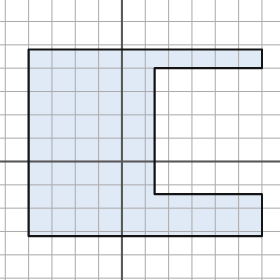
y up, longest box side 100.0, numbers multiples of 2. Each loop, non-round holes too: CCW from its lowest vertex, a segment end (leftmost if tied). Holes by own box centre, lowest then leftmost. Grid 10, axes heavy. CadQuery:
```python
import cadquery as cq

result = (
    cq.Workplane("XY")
    .moveTo(-40.0, -32.0)
    .lineTo(60.0, -32.0)
    .lineTo(60.0, -14.0)
    .lineTo(14.0, -14.0)
    .lineTo(14.0, 40.0)
    .lineTo(60.0, 40.0)
    .lineTo(60.0, 48.0)
    .lineTo(-40.0, 48.0)
    .close()
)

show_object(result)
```